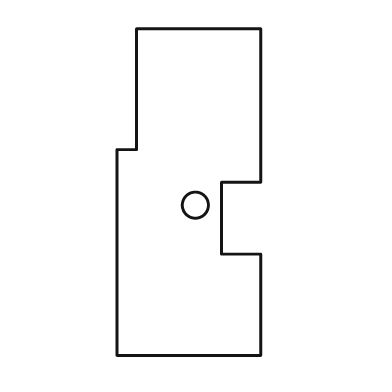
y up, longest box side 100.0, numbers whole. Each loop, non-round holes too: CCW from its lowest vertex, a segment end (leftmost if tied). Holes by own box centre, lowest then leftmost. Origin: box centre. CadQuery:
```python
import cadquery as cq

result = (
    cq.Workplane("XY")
    .moveTo(-22.0, -50.0)
    .lineTo(22.0, -50.0)
    .lineTo(22.0, -19.0)
    .lineTo(10.0, -19.0)
    .lineTo(10.0, 3.0)
    .lineTo(22.0, 3.0)
    .lineTo(22.0, 50.0)
    .lineTo(-16.0, 50.0)
    .lineTo(-16.0, 13.0)
    .lineTo(-22.0, 13.0)
    .close()
    .moveTo(2.0, -4.0)
    .circle(4.0)
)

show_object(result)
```